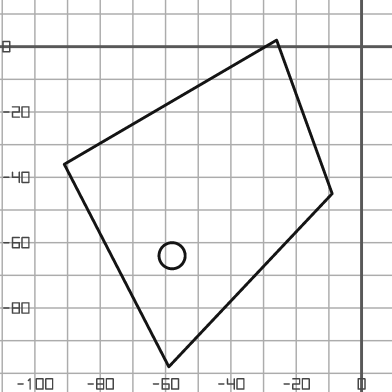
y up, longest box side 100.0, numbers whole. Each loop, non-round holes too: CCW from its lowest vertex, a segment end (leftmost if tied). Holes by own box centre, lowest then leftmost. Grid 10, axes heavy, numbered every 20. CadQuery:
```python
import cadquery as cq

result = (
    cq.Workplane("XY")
    .moveTo(-59.0, -98.0)
    .lineTo(-9.0, -45.0)
    .lineTo(-26.0, 2.0)
    .lineTo(-91.0, -36.0)
    .close()
    .moveTo(-58.0, -64.0)
    .circle(4.0)
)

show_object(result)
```